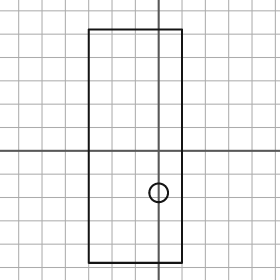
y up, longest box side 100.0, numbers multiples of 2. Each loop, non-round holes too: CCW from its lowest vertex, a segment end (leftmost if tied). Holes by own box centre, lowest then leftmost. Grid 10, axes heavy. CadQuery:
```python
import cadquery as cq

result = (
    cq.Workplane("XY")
    .moveTo(-30.0, -48.0)
    .lineTo(10.0, -48.0)
    .lineTo(10.0, 52.0)
    .lineTo(-30.0, 52.0)
    .close()
    .moveTo(0.0, -18.0)
    .circle(4.0)
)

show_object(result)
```